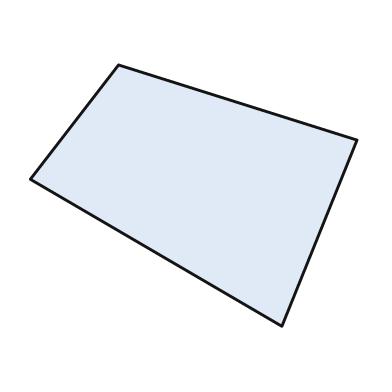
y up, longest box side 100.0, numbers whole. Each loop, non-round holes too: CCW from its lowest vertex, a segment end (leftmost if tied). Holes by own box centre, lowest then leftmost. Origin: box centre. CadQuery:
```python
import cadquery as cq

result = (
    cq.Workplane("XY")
    .moveTo(27.0, -40.0)
    .lineTo(50.0, 17.0)
    .lineTo(-23.0, 40.0)
    .lineTo(-50.0, 5.0)
    .close()
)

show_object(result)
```